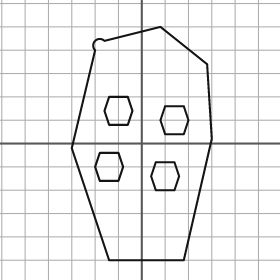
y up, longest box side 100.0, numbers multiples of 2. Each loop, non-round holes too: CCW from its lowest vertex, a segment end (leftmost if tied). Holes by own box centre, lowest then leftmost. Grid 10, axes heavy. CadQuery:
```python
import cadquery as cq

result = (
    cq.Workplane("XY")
    .moveTo(-14.0, -50.0)
    .lineTo(18.0, -50.0)
    .lineTo(30.0, 2.0)
    .lineTo(28.0, 34.0)
    .lineTo(8.0, 50.0)
    .lineTo(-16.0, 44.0)
    .threePointArc((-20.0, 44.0), (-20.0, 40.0))
    .lineTo(-30.0, -2.0)
    .close()
    .moveTo(6.0, -20.0)
    .lineTo(14.0, -20.0)
    .lineTo(16.0, -14.0)
    .lineTo(14.0, -8.0)
    .lineTo(6.0, -8.0)
    .lineTo(4.0, -14.0)
    .close()
    .moveTo(-18.0, -16.0)
    .lineTo(-10.0, -16.0)
    .lineTo(-8.0, -10.0)
    .lineTo(-10.0, -4.0)
    .lineTo(-18.0, -4.0)
    .lineTo(-20.0, -10.0)
    .close()
    .moveTo(10.0, 4.0)
    .lineTo(18.0, 4.0)
    .lineTo(20.0, 10.0)
    .lineTo(18.0, 16.0)
    .lineTo(10.0, 16.0)
    .lineTo(8.0, 10.0)
    .close()
    .moveTo(-14.0, 8.0)
    .lineTo(-6.0, 8.0)
    .lineTo(-4.0, 14.0)
    .lineTo(-6.0, 20.0)
    .lineTo(-14.0, 20.0)
    .lineTo(-16.0, 14.0)
    .close()
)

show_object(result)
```